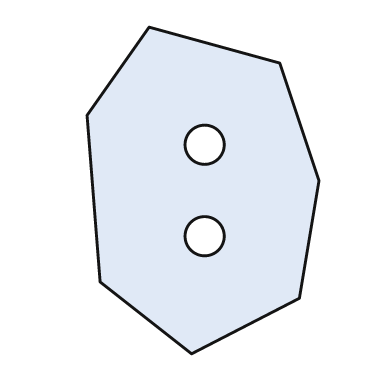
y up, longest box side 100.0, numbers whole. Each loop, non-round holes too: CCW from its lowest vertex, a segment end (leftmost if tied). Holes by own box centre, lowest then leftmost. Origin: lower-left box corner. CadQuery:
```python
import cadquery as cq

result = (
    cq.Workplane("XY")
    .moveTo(32.0, 0.0)
    .lineTo(65.0, 17.0)
    .lineTo(71.0, 53.0)
    .lineTo(59.0, 89.0)
    .lineTo(19.0, 100.0)
    .lineTo(0.0, 73.0)
    .lineTo(4.0, 22.0)
    .close()
    .moveTo(36.0, 36.0)
    .circle(6.0)
    .moveTo(36.0, 64.0)
    .circle(6.0)
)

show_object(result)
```